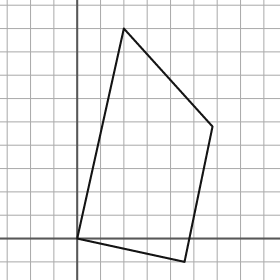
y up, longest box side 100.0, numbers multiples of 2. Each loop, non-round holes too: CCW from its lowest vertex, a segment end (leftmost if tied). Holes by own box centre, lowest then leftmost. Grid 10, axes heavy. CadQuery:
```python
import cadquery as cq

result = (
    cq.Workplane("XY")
    .moveTo(46.0, -10.0)
    .lineTo(58.0, 48.0)
    .lineTo(20.0, 90.0)
    .lineTo(0.0, 0.0)
    .close()
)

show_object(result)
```